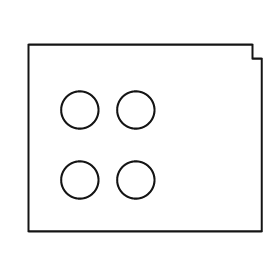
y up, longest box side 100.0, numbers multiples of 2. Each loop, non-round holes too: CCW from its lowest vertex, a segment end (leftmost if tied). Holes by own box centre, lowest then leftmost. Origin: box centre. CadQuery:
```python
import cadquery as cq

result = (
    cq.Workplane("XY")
    .moveTo(-50.0, -40.0)
    .lineTo(50.0, -40.0)
    .lineTo(50.0, 34.0)
    .lineTo(46.0, 34.0)
    .lineTo(46.0, 40.0)
    .lineTo(-50.0, 40.0)
    .close()
    .moveTo(-28.0, -18.0)
    .circle(8.0)
    .moveTo(-4.0, -18.0)
    .circle(8.0)
    .moveTo(-28.0, 12.0)
    .circle(8.0)
    .moveTo(-4.0, 12.0)
    .circle(8.0)
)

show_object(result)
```